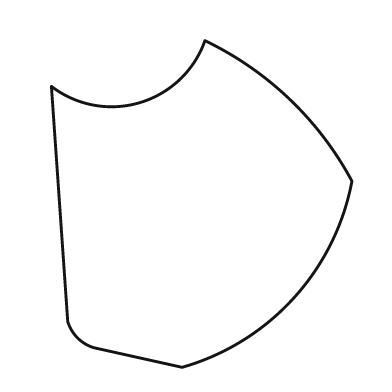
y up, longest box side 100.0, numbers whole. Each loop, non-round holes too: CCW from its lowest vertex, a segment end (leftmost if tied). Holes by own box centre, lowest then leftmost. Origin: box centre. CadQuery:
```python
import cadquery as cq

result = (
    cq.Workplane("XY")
    .moveTo(-6.0, -50.0)
    .threePointArc((28.0, -29.0), (46.0, 7.0))
    .threePointArc((27.0, 32.0), (1.0, 50.0))
    .threePointArc((-19.0, 31.0), (-46.0, 36.0))
    .lineTo(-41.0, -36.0)
    .threePointArc((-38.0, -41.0), (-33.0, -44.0))
    .close()
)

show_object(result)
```